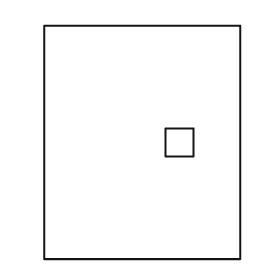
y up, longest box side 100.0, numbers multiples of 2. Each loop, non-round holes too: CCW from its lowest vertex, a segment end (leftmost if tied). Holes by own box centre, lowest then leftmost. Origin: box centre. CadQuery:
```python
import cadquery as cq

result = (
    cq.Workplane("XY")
    .moveTo(-42.0, -50.0)
    .lineTo(42.0, -50.0)
    .lineTo(42.0, 50.0)
    .lineTo(-42.0, 50.0)
    .close()
    .moveTo(10.0, -6.0)
    .lineTo(22.0, -6.0)
    .lineTo(22.0, 6.0)
    .lineTo(10.0, 6.0)
    .close()
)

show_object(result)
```